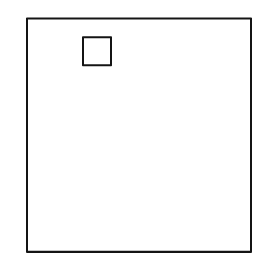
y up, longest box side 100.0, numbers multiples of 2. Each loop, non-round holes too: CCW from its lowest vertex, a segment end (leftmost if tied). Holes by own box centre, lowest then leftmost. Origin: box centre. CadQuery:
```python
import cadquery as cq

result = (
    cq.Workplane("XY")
    .moveTo(-48.0, -50.0)
    .lineTo(48.0, -50.0)
    .lineTo(48.0, 50.0)
    .lineTo(-48.0, 50.0)
    .close()
    .moveTo(-24.0, 30.0)
    .lineTo(-12.0, 30.0)
    .lineTo(-12.0, 42.0)
    .lineTo(-24.0, 42.0)
    .close()
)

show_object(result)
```